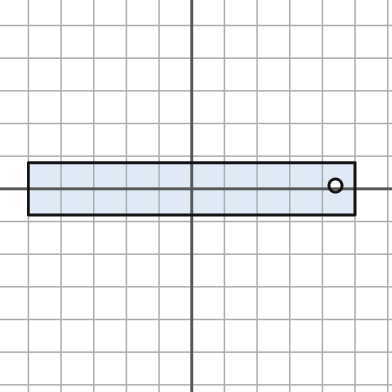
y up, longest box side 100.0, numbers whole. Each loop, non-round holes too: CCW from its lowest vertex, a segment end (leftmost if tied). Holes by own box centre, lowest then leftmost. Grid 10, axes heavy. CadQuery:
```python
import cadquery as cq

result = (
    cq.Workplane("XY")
    .moveTo(-50.0, -8.0)
    .lineTo(50.0, -8.0)
    .lineTo(50.0, 8.0)
    .lineTo(-50.0, 8.0)
    .close()
    .moveTo(44.0, 1.0)
    .circle(2.0)
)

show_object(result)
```